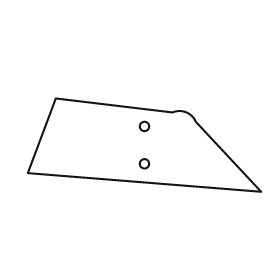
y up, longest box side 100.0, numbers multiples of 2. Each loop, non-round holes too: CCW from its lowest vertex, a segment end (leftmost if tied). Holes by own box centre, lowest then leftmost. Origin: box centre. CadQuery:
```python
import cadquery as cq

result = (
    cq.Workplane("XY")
    .moveTo(50.0, -20.0)
    .lineTo(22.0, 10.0)
    .threePointArc((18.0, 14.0), (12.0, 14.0))
    .lineTo(-38.0, 20.0)
    .lineTo(-50.0, -12.0)
    .close()
    .moveTo(0.0, -8.0)
    .circle(2.0)
    .moveTo(0.0, 8.0)
    .circle(2.0)
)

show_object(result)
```